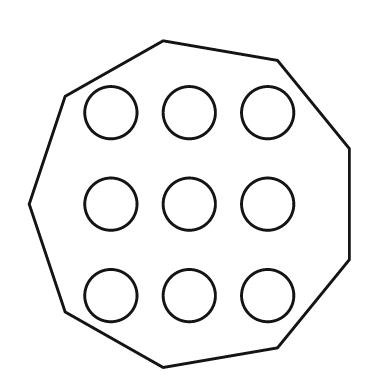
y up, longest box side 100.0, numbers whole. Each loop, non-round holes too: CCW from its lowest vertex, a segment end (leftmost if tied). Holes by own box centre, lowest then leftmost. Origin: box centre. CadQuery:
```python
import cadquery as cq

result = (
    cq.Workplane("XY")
    .moveTo(-8.0, -50.0)
    .lineTo(27.0, -44.0)
    .lineTo(49.0, -17.0)
    .lineTo(49.0, 17.0)
    .lineTo(27.0, 44.0)
    .lineTo(-8.0, 50.0)
    .lineTo(-38.0, 33.0)
    .lineTo(-49.0, 0.0)
    .lineTo(-38.0, -33.0)
    .close()
    .moveTo(-24.0, -28.0)
    .circle(8.0)
    .moveTo(0.0, -28.0)
    .circle(8.0)
    .moveTo(24.0, -28.0)
    .circle(8.0)
    .moveTo(-24.0, 0.0)
    .circle(8.0)
    .moveTo(0.0, 0.0)
    .circle(8.0)
    .moveTo(24.0, 0.0)
    .circle(8.0)
    .moveTo(-24.0, 28.0)
    .circle(8.0)
    .moveTo(0.0, 28.0)
    .circle(8.0)
    .moveTo(24.0, 28.0)
    .circle(8.0)
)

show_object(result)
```